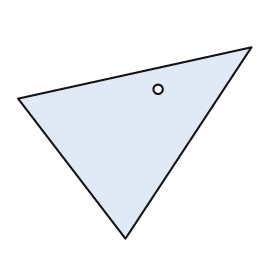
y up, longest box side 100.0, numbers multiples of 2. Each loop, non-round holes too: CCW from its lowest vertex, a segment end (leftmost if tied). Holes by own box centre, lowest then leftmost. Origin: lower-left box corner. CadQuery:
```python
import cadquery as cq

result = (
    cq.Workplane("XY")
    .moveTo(46.0, 0.0)
    .lineTo(100.0, 82.0)
    .lineTo(0.0, 60.0)
    .close()
    .moveTo(60.0, 64.0)
    .circle(2.0)
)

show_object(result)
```